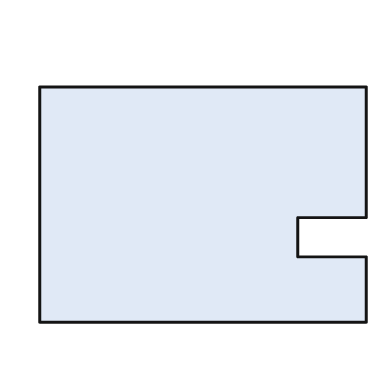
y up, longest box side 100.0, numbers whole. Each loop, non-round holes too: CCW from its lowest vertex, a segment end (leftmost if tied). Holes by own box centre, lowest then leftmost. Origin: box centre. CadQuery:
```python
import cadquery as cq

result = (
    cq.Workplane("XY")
    .moveTo(-50.0, -36.0)
    .lineTo(50.0, -36.0)
    .lineTo(50.0, -16.0)
    .lineTo(29.0, -16.0)
    .lineTo(29.0, -4.0)
    .lineTo(50.0, -4.0)
    .lineTo(50.0, 36.0)
    .lineTo(-50.0, 36.0)
    .close()
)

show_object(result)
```